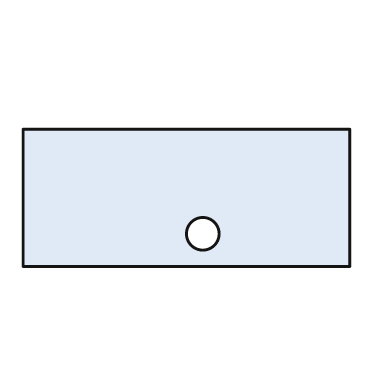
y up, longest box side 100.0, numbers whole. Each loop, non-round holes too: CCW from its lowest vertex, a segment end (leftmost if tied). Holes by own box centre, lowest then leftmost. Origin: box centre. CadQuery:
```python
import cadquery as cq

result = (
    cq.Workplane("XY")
    .moveTo(-50.0, -21.0)
    .lineTo(50.0, -21.0)
    .lineTo(50.0, 21.0)
    .lineTo(-50.0, 21.0)
    .close()
    .moveTo(5.0, -11.0)
    .circle(5.0)
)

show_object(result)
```